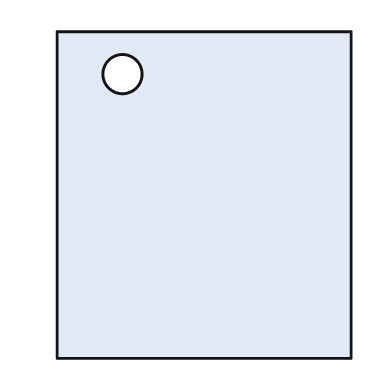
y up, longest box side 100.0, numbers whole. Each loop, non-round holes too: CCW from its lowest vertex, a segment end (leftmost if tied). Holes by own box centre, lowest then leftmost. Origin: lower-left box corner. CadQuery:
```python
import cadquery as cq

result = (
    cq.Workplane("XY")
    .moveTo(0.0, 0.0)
    .lineTo(90.0, 0.0)
    .lineTo(90.0, 100.0)
    .lineTo(0.0, 100.0)
    .close()
    .moveTo(20.0, 87.0)
    .circle(6.0)
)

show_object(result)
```